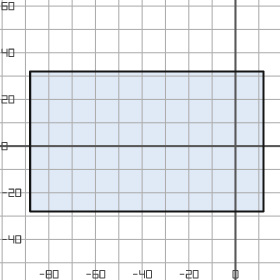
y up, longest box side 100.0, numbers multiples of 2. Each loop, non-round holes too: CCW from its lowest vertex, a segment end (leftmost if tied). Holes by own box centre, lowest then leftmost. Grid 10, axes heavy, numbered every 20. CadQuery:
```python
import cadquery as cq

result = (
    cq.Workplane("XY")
    .moveTo(-88.0, -28.0)
    .lineTo(12.0, -28.0)
    .lineTo(12.0, 32.0)
    .lineTo(-88.0, 32.0)
    .close()
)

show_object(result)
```